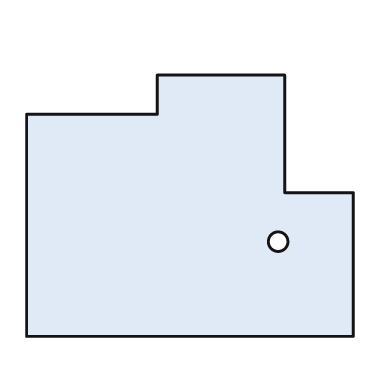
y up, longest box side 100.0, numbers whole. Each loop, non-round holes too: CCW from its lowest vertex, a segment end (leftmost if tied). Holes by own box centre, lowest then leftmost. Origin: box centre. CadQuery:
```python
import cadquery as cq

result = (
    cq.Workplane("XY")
    .moveTo(-50.0, -40.0)
    .lineTo(50.0, -40.0)
    .lineTo(50.0, 4.0)
    .lineTo(29.0, 4.0)
    .lineTo(29.0, 40.0)
    .lineTo(-10.0, 40.0)
    .lineTo(-10.0, 28.0)
    .lineTo(-50.0, 28.0)
    .close()
    .moveTo(27.0, -11.0)
    .circle(3.0)
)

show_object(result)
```